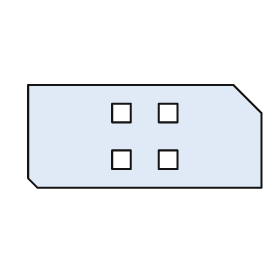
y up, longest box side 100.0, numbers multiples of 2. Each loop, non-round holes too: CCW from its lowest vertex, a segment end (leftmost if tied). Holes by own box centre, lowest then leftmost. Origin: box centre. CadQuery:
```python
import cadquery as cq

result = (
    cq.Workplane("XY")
    .moveTo(-46.0, -22.0)
    .lineTo(50.0, -22.0)
    .lineTo(50.0, 10.0)
    .lineTo(38.0, 22.0)
    .lineTo(-50.0, 22.0)
    .lineTo(-50.0, -18.0)
    .close()
    .moveTo(-14.0, -14.0)
    .lineTo(-6.0, -14.0)
    .lineTo(-6.0, -6.0)
    .lineTo(-14.0, -6.0)
    .close()
    .moveTo(6.0, -14.0)
    .lineTo(14.0, -14.0)
    .lineTo(14.0, -6.0)
    .lineTo(6.0, -6.0)
    .close()
    .moveTo(-14.0, 6.0)
    .lineTo(-6.0, 6.0)
    .lineTo(-6.0, 14.0)
    .lineTo(-14.0, 14.0)
    .close()
    .moveTo(6.0, 6.0)
    .lineTo(14.0, 6.0)
    .lineTo(14.0, 14.0)
    .lineTo(6.0, 14.0)
    .close()
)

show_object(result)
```